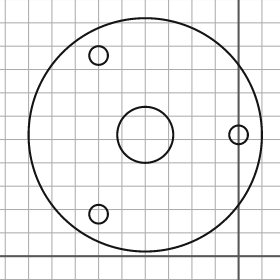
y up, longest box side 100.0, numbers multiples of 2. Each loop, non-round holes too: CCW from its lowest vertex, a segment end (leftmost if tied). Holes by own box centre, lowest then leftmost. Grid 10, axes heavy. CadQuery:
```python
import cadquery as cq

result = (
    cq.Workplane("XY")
    .moveTo(-40.0, 52.0)
    .circle(50.0)
    .moveTo(-60.0, 18.0)
    .circle(4.0)
    .moveTo(-40.0, 52.0)
    .circle(12.0)
    .moveTo(0.0, 52.0)
    .circle(4.0)
    .moveTo(-60.0, 86.0)
    .circle(4.0)
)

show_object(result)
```